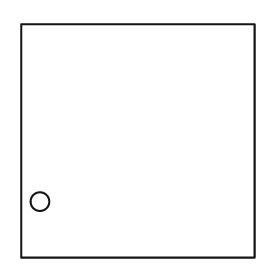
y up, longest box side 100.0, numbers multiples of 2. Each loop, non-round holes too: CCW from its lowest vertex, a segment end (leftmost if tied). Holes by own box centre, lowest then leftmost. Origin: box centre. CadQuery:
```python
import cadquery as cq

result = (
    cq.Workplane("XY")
    .moveTo(-50.0, -50.0)
    .lineTo(50.0, -50.0)
    .lineTo(50.0, 50.0)
    .lineTo(-50.0, 50.0)
    .close()
    .moveTo(-42.0, -26.0)
    .circle(4.0)
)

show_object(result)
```